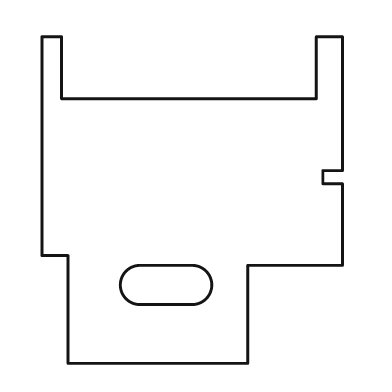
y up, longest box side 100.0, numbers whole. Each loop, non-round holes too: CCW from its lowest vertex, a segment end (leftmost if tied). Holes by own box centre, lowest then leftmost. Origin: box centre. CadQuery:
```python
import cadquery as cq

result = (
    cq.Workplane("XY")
    .moveTo(-38.0, -50.0)
    .lineTo(17.0, -50.0)
    .lineTo(17.0, -20.0)
    .lineTo(46.0, -20.0)
    .lineTo(46.0, 5.0)
    .lineTo(40.0, 5.0)
    .lineTo(40.0, 9.0)
    .lineTo(46.0, 9.0)
    .lineTo(46.0, 50.0)
    .lineTo(38.0, 50.0)
    .lineTo(38.0, 31.0)
    .lineTo(-40.0, 31.0)
    .lineTo(-40.0, 50.0)
    .lineTo(-46.0, 50.0)
    .lineTo(-46.0, -17.0)
    .lineTo(-38.0, -17.0)
    .close()
    .moveTo(-16.0, -32.0)
    .lineTo(0.0, -32.0)
    .threePointArc((6.0, -26.0), (0.0, -20.0))
    .lineTo(-16.0, -20.0)
    .threePointArc((-22.0, -26.0), (-16.0, -32.0))
    .close()
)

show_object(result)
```